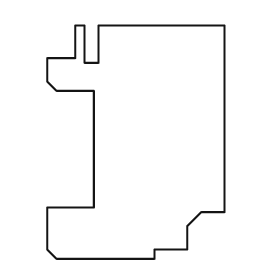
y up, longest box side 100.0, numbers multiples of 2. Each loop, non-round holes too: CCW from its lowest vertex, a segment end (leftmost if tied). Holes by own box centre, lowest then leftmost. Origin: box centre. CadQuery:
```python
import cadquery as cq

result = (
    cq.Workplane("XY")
    .moveTo(-34.0, -50.0)
    .lineTo(8.0, -50.0)
    .lineTo(8.0, -46.0)
    .lineTo(22.0, -46.0)
    .lineTo(22.0, -36.0)
    .lineTo(28.0, -30.0)
    .lineTo(38.0, -30.0)
    .lineTo(38.0, 50.0)
    .lineTo(-16.0, 50.0)
    .lineTo(-16.0, 34.0)
    .lineTo(-22.0, 34.0)
    .lineTo(-22.0, 50.0)
    .lineTo(-26.0, 50.0)
    .lineTo(-26.0, 36.0)
    .lineTo(-38.0, 36.0)
    .lineTo(-38.0, 26.0)
    .lineTo(-34.0, 22.0)
    .lineTo(-18.0, 22.0)
    .lineTo(-18.0, -28.0)
    .lineTo(-38.0, -28.0)
    .lineTo(-38.0, -46.0)
    .close()
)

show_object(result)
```